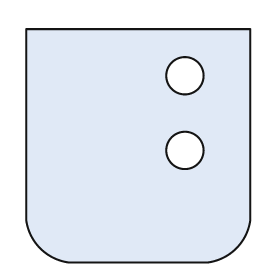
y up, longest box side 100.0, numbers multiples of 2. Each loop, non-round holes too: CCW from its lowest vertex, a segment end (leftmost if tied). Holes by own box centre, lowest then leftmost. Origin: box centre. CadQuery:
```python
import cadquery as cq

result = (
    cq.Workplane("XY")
    .moveTo(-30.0, -50.0)
    .lineTo(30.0, -50.0)
    .threePointArc((42.0, -44.0), (48.0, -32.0))
    .lineTo(48.0, 50.0)
    .lineTo(-48.0, 50.0)
    .lineTo(-48.0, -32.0)
    .threePointArc((-42.0, -44.0), (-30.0, -50.0))
    .close()
    .moveTo(20.0, -2.0)
    .circle(8.0)
    .moveTo(20.0, 30.0)
    .circle(8.0)
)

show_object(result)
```